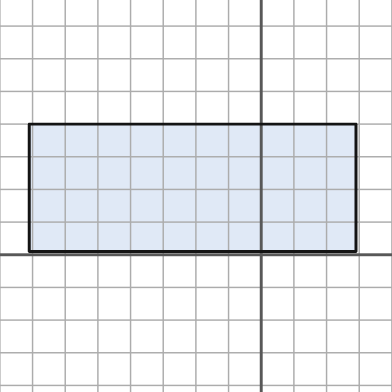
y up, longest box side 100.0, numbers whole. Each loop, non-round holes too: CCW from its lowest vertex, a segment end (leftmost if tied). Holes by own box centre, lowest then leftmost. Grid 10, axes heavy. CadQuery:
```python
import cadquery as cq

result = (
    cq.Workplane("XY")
    .moveTo(-71.0, 1.0)
    .lineTo(29.0, 1.0)
    .lineTo(29.0, 40.0)
    .lineTo(-71.0, 40.0)
    .close()
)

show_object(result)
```